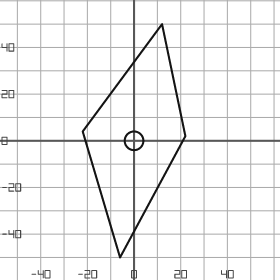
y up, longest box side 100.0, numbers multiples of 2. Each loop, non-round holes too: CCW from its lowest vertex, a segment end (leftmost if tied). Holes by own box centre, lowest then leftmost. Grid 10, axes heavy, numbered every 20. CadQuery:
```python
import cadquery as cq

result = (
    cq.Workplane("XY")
    .moveTo(-6.0, -50.0)
    .lineTo(22.0, 2.0)
    .lineTo(12.0, 50.0)
    .lineTo(-22.0, 4.0)
    .close()
    .moveTo(0.0, 0.0)
    .circle(4.0)
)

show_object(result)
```